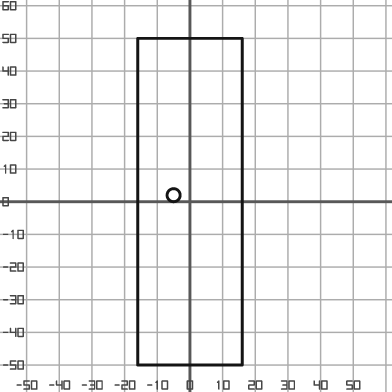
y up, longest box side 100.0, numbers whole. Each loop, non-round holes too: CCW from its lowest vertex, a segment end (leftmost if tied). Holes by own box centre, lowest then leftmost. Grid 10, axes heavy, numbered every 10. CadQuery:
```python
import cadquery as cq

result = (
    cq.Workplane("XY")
    .moveTo(-16.0, -50.0)
    .lineTo(16.0, -50.0)
    .lineTo(16.0, 50.0)
    .lineTo(-16.0, 50.0)
    .close()
    .moveTo(-5.0, 2.0)
    .circle(2.0)
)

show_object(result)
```